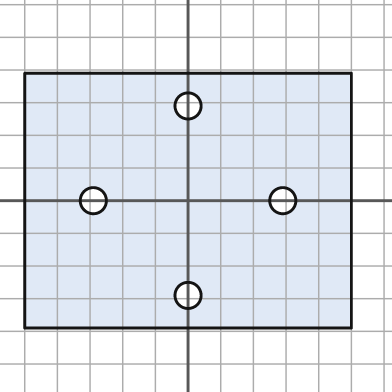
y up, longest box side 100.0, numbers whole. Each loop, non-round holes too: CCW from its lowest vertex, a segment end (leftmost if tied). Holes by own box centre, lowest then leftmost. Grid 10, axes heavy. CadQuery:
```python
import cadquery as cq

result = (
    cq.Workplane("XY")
    .moveTo(-50.0, -39.0)
    .lineTo(50.0, -39.0)
    .lineTo(50.0, 39.0)
    .lineTo(-50.0, 39.0)
    .close()
    .moveTo(0.0, -29.0)
    .circle(4.0)
    .moveTo(-29.0, 0.0)
    .circle(4.0)
    .moveTo(29.0, 0.0)
    .circle(4.0)
    .moveTo(0.0, 29.0)
    .circle(4.0)
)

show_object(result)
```